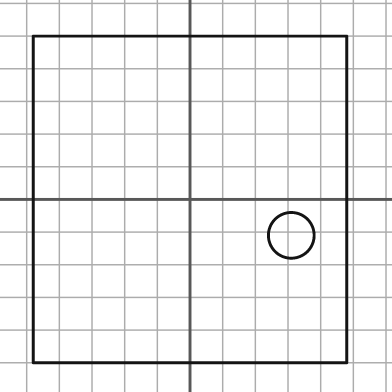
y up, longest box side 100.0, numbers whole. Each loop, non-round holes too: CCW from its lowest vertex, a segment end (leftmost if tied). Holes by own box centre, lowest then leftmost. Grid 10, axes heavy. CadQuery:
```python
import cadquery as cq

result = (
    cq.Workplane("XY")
    .moveTo(-48.0, -50.0)
    .lineTo(48.0, -50.0)
    .lineTo(48.0, 50.0)
    .lineTo(-48.0, 50.0)
    .close()
    .moveTo(31.0, -11.0)
    .circle(7.0)
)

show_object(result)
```